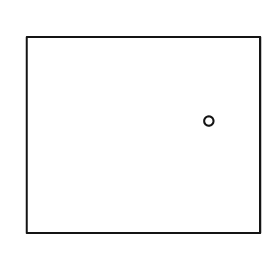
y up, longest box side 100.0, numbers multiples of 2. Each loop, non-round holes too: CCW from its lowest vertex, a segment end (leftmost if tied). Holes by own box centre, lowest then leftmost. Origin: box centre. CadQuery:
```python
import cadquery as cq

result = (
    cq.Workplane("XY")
    .moveTo(-50.0, -42.0)
    .lineTo(50.0, -42.0)
    .lineTo(50.0, 42.0)
    .lineTo(-50.0, 42.0)
    .close()
    .moveTo(28.0, 6.0)
    .circle(2.0)
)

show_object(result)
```